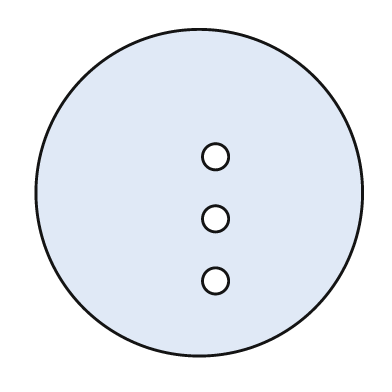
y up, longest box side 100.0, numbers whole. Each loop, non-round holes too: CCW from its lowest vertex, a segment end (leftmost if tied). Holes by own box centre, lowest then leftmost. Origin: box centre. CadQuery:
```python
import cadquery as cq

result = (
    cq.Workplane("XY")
    .moveTo(0.0, 0.0)
    .circle(50.0)
    .moveTo(5.0, -27.0)
    .circle(4.0)
    .moveTo(5.0, -8.0)
    .circle(4.0)
    .moveTo(5.0, 11.0)
    .circle(4.0)
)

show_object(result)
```